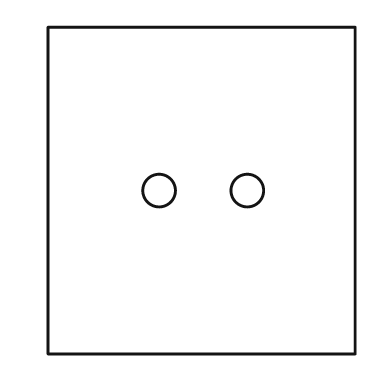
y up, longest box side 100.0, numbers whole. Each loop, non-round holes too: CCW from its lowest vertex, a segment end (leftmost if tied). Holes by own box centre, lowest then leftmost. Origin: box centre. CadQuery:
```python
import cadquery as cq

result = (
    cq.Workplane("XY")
    .moveTo(-47.0, -50.0)
    .lineTo(47.0, -50.0)
    .lineTo(47.0, 50.0)
    .lineTo(-47.0, 50.0)
    .close()
    .moveTo(-13.0, 0.0)
    .circle(5.0)
    .moveTo(14.0, 0.0)
    .circle(5.0)
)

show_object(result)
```